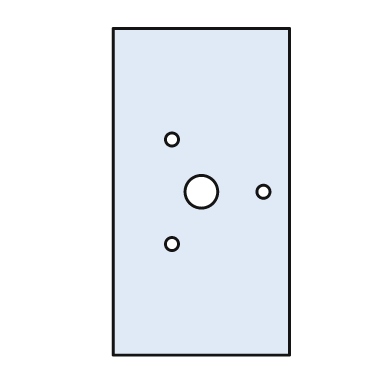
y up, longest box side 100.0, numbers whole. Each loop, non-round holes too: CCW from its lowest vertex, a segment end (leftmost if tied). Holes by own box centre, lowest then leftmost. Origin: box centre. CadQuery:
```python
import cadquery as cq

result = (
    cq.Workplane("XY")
    .moveTo(-27.0, -50.0)
    .lineTo(27.0, -50.0)
    .lineTo(27.0, 50.0)
    .lineTo(-27.0, 50.0)
    .close()
    .moveTo(-9.0, -16.0)
    .circle(2.0)
    .moveTo(0.0, 0.0)
    .circle(5.0)
    .moveTo(19.0, 0.0)
    .circle(2.0)
    .moveTo(-9.0, 16.0)
    .circle(2.0)
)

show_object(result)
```